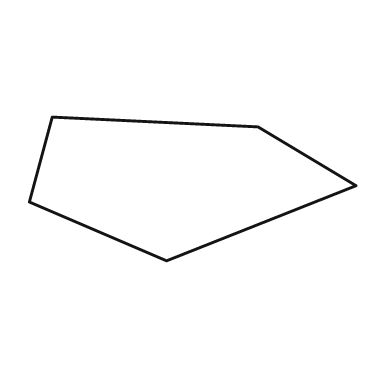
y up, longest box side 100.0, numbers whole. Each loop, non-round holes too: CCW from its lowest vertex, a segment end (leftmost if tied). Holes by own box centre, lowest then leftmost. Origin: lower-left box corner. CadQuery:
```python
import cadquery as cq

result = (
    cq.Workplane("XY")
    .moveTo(42.0, 0.0)
    .lineTo(100.0, 23.0)
    .lineTo(70.0, 41.0)
    .lineTo(7.0, 44.0)
    .lineTo(0.0, 18.0)
    .close()
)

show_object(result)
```